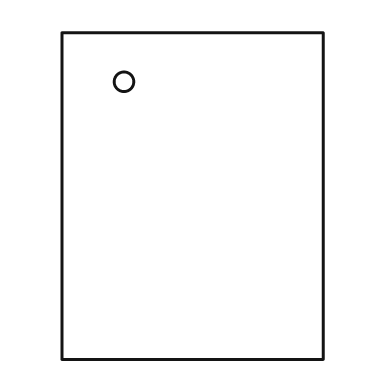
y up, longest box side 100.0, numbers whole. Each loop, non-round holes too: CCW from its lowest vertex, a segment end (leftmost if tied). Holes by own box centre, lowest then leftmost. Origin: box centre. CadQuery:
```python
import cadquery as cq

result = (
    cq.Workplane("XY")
    .moveTo(-40.0, -50.0)
    .lineTo(40.0, -50.0)
    .lineTo(40.0, 50.0)
    .lineTo(-40.0, 50.0)
    .close()
    .moveTo(-21.0, 35.0)
    .circle(3.0)
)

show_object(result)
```